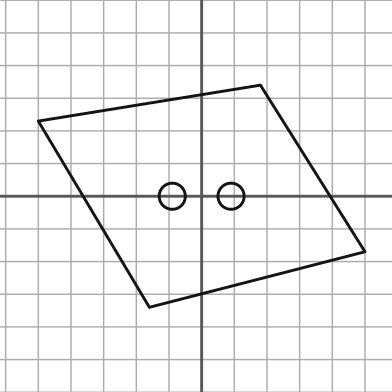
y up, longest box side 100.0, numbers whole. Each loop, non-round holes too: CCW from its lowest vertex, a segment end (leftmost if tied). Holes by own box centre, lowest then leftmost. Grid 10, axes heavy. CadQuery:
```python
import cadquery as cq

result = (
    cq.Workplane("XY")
    .moveTo(-16.0, -34.0)
    .lineTo(50.0, -17.0)
    .lineTo(18.0, 34.0)
    .lineTo(-50.0, 23.0)
    .close()
    .moveTo(-9.0, 0.0)
    .circle(4.0)
    .moveTo(9.0, 0.0)
    .circle(4.0)
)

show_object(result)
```